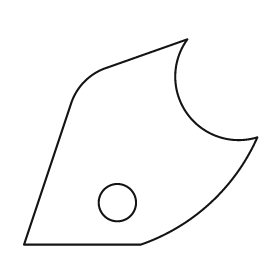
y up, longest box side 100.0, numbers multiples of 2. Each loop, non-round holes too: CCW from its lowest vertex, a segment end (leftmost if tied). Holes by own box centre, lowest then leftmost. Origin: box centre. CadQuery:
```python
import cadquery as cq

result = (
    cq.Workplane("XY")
    .moveTo(-50.0, -44.0)
    .lineTo(0.0, -44.0)
    .threePointArc((30.0, -26.0), (50.0, 2.0))
    .threePointArc((20.0, 12.0), (20.0, 44.0))
    .lineTo(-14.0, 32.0)
    .threePointArc((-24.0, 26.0), (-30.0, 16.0))
    .close()
    .moveTo(-10.0, -26.0)
    .circle(8.0)
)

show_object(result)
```